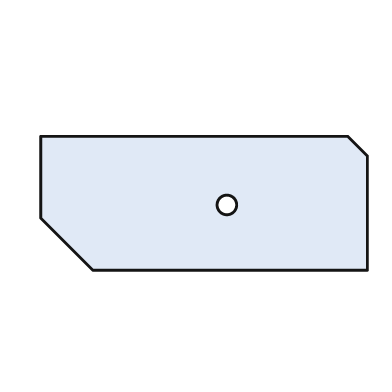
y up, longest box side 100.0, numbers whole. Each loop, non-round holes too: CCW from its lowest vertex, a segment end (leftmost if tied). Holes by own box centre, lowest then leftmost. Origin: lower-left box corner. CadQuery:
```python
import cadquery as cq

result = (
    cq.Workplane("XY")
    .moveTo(16.0, 0.0)
    .lineTo(100.0, 0.0)
    .lineTo(100.0, 35.0)
    .lineTo(94.0, 41.0)
    .lineTo(0.0, 41.0)
    .lineTo(0.0, 16.0)
    .close()
    .moveTo(57.0, 20.0)
    .circle(3.0)
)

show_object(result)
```